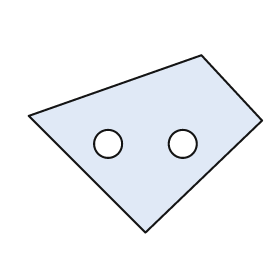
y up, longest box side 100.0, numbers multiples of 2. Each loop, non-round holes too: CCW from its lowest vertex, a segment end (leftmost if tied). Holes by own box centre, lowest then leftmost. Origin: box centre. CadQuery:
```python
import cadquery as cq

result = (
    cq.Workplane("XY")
    .moveTo(0.0, -38.0)
    .lineTo(50.0, 10.0)
    .lineTo(24.0, 38.0)
    .lineTo(-50.0, 12.0)
    .close()
    .moveTo(-16.0, 0.0)
    .circle(6.0)
    .moveTo(16.0, 0.0)
    .circle(6.0)
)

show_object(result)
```